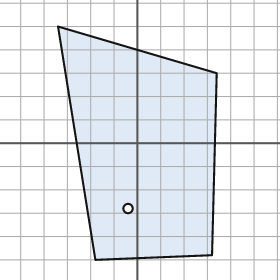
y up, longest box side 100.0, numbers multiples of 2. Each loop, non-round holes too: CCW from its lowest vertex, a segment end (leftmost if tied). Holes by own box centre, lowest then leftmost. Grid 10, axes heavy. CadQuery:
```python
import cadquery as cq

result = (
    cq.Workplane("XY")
    .moveTo(-18.0, -50.0)
    .lineTo(32.0, -48.0)
    .lineTo(34.0, 30.0)
    .lineTo(-34.0, 50.0)
    .close()
    .moveTo(-4.0, -28.0)
    .circle(2.0)
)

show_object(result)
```